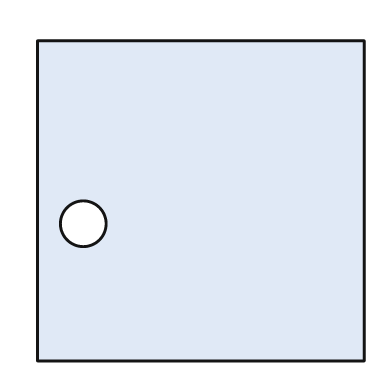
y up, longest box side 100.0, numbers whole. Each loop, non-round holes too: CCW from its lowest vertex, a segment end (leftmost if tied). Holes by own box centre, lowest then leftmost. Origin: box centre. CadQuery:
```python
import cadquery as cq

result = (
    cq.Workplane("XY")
    .moveTo(-50.0, -49.0)
    .lineTo(50.0, -49.0)
    .lineTo(50.0, 49.0)
    .lineTo(-50.0, 49.0)
    .close()
    .moveTo(-36.0, -7.0)
    .circle(7.0)
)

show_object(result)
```